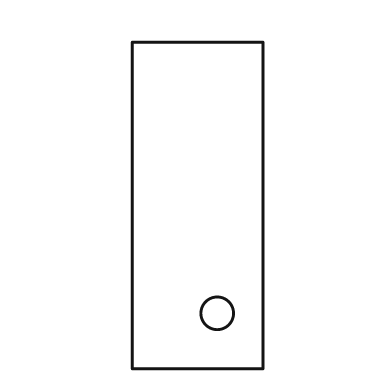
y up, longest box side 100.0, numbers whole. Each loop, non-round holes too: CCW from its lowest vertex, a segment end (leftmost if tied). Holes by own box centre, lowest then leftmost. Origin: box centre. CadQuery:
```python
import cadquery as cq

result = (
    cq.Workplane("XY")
    .moveTo(-20.0, -50.0)
    .lineTo(20.0, -50.0)
    .lineTo(20.0, 50.0)
    .lineTo(-20.0, 50.0)
    .close()
    .moveTo(6.0, -33.0)
    .circle(5.0)
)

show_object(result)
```